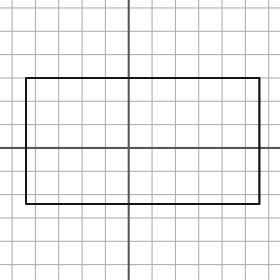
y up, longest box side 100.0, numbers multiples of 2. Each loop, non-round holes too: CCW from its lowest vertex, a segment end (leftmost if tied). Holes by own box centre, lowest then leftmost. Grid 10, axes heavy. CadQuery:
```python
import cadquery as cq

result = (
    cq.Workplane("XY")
    .moveTo(-44.0, -24.0)
    .lineTo(56.0, -24.0)
    .lineTo(56.0, 30.0)
    .lineTo(-44.0, 30.0)
    .close()
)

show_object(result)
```